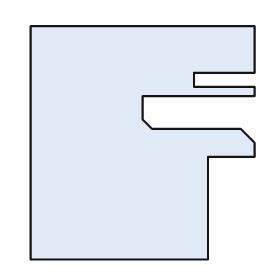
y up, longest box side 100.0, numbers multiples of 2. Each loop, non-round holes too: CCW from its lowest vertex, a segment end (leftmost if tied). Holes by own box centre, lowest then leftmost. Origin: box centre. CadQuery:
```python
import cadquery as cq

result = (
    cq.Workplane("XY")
    .moveTo(-48.0, -50.0)
    .lineTo(28.0, -50.0)
    .lineTo(28.0, -6.0)
    .lineTo(48.0, -6.0)
    .lineTo(48.0, 0.0)
    .lineTo(42.0, 6.0)
    .lineTo(4.0, 6.0)
    .lineTo(0.0, 10.0)
    .lineTo(0.0, 20.0)
    .lineTo(48.0, 20.0)
    .lineTo(48.0, 24.0)
    .lineTo(22.0, 24.0)
    .lineTo(22.0, 30.0)
    .lineTo(48.0, 30.0)
    .lineTo(48.0, 50.0)
    .lineTo(-48.0, 50.0)
    .close()
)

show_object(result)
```